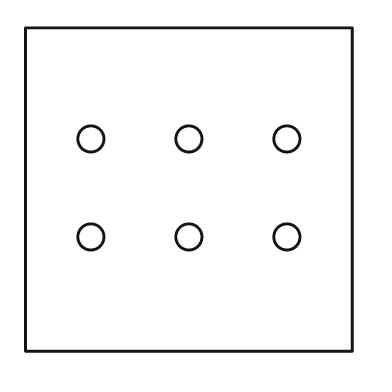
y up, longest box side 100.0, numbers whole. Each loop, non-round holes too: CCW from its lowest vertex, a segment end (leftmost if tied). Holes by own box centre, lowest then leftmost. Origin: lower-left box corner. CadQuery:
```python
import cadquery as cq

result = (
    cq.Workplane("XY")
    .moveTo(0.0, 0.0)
    .lineTo(100.0, 0.0)
    .lineTo(100.0, 99.0)
    .lineTo(0.0, 99.0)
    .close()
    .moveTo(20.0, 35.0)
    .circle(4.0)
    .moveTo(50.0, 35.0)
    .circle(4.0)
    .moveTo(80.0, 35.0)
    .circle(4.0)
    .moveTo(20.0, 65.0)
    .circle(4.0)
    .moveTo(50.0, 65.0)
    .circle(4.0)
    .moveTo(80.0, 65.0)
    .circle(4.0)
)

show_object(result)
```